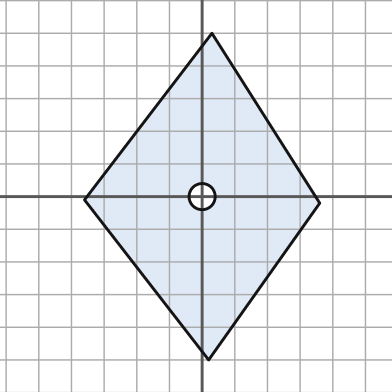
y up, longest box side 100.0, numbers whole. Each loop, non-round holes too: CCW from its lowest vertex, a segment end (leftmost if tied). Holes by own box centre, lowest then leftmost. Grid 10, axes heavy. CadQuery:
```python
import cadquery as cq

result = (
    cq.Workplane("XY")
    .moveTo(2.0, -50.0)
    .lineTo(36.0, -2.0)
    .lineTo(3.0, 50.0)
    .lineTo(-36.0, -1.0)
    .close()
    .moveTo(0.0, 0.0)
    .circle(4.0)
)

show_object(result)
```